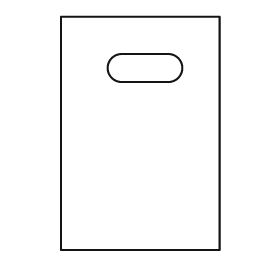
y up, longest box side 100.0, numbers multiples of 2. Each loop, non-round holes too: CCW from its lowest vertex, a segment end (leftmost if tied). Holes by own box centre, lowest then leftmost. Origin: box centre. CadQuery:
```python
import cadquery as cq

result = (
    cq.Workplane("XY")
    .moveTo(-34.0, -50.0)
    .lineTo(34.0, -50.0)
    .lineTo(34.0, 50.0)
    .lineTo(-34.0, 50.0)
    .close()
    .moveTo(-8.0, 22.0)
    .lineTo(12.0, 22.0)
    .threePointArc((18.0, 28.0), (12.0, 34.0))
    .lineTo(-8.0, 34.0)
    .threePointArc((-14.0, 28.0), (-8.0, 22.0))
    .close()
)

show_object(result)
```